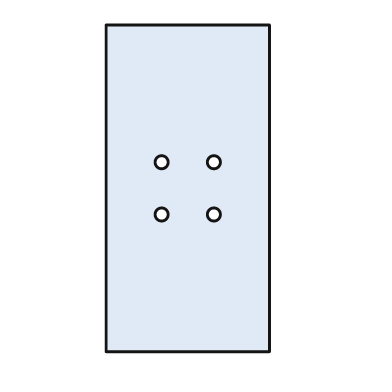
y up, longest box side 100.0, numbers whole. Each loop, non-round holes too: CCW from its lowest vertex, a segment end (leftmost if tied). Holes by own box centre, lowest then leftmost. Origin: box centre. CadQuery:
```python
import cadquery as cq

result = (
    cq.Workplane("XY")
    .moveTo(-25.0, -50.0)
    .lineTo(25.0, -50.0)
    .lineTo(25.0, 50.0)
    .lineTo(-25.0, 50.0)
    .close()
    .moveTo(-8.0, -8.0)
    .circle(2.0)
    .moveTo(8.0, -8.0)
    .circle(2.0)
    .moveTo(-8.0, 8.0)
    .circle(2.0)
    .moveTo(8.0, 8.0)
    .circle(2.0)
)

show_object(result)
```